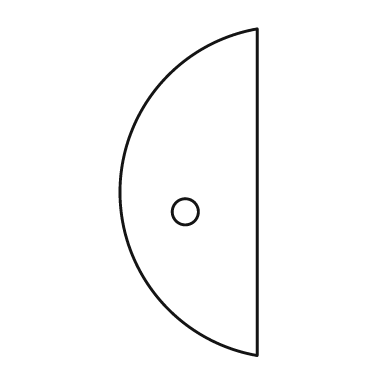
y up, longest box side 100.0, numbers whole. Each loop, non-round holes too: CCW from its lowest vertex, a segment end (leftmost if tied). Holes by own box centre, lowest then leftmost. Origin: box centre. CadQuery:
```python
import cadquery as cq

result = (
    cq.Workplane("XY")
    .moveTo(21.0, -50.0)
    .lineTo(21.0, 50.0)
    .threePointArc((-21.0, 0.0), (21.0, -50.0))
    .close()
    .moveTo(-1.0, -6.0)
    .circle(4.0)
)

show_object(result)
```